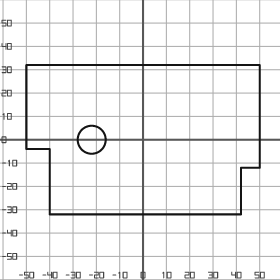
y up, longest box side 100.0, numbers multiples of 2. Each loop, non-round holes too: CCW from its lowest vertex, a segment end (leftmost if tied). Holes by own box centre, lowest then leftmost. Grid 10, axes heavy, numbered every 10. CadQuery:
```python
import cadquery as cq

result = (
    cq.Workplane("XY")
    .moveTo(-40.0, -32.0)
    .lineTo(42.0, -32.0)
    .lineTo(42.0, -12.0)
    .lineTo(50.0, -12.0)
    .lineTo(50.0, 32.0)
    .lineTo(-50.0, 32.0)
    .lineTo(-50.0, -4.0)
    .lineTo(-40.0, -4.0)
    .close()
    .moveTo(-22.0, 0.0)
    .circle(6.0)
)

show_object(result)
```